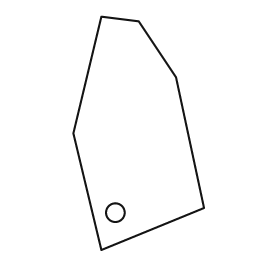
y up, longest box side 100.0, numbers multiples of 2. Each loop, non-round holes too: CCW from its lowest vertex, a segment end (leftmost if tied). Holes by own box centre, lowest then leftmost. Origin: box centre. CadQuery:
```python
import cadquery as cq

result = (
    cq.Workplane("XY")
    .moveTo(-16.0, -50.0)
    .lineTo(28.0, -32.0)
    .lineTo(16.0, 24.0)
    .lineTo(0.0, 48.0)
    .lineTo(-16.0, 50.0)
    .lineTo(-28.0, 0.0)
    .close()
    .moveTo(-10.0, -34.0)
    .circle(4.0)
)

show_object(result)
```